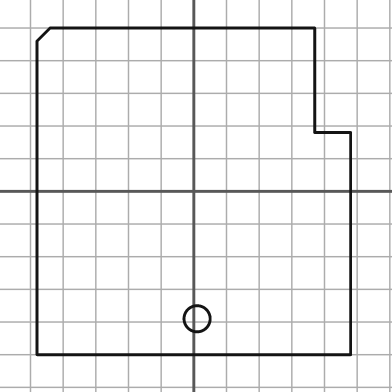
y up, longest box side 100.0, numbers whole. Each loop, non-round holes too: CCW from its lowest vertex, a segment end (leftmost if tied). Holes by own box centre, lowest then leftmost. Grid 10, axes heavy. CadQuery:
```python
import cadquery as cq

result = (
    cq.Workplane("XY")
    .moveTo(-48.0, -50.0)
    .lineTo(48.0, -50.0)
    .lineTo(48.0, 18.0)
    .lineTo(37.0, 18.0)
    .lineTo(37.0, 50.0)
    .lineTo(-44.0, 50.0)
    .lineTo(-48.0, 46.0)
    .close()
    .moveTo(1.0, -39.0)
    .circle(4.0)
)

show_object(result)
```